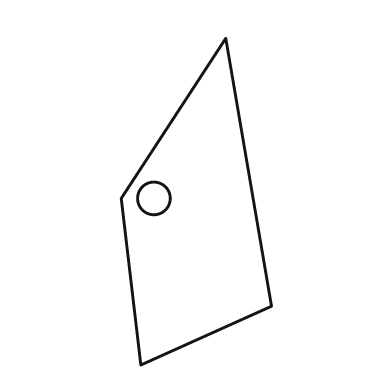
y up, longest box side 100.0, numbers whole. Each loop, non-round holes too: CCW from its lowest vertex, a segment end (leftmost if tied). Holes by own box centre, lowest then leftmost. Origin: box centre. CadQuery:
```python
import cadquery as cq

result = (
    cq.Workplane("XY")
    .moveTo(-17.0, -50.0)
    .lineTo(23.0, -32.0)
    .lineTo(9.0, 50.0)
    .lineTo(-23.0, 1.0)
    .close()
    .moveTo(-13.0, 1.0)
    .circle(5.0)
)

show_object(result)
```